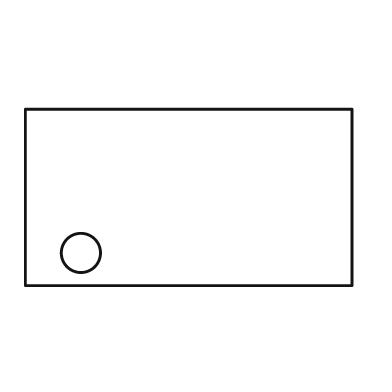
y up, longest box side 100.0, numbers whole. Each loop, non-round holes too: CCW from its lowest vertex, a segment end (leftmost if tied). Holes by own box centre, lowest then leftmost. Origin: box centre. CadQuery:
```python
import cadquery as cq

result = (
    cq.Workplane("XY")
    .moveTo(-50.0, -27.0)
    .lineTo(50.0, -27.0)
    .lineTo(50.0, 27.0)
    .lineTo(-50.0, 27.0)
    .close()
    .moveTo(-33.0, -17.0)
    .circle(6.0)
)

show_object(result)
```